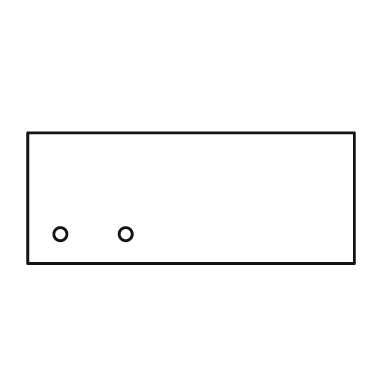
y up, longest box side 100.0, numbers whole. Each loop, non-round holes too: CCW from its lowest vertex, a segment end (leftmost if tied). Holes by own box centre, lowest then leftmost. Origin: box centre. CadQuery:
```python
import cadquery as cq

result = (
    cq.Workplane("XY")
    .moveTo(-50.0, -20.0)
    .lineTo(50.0, -20.0)
    .lineTo(50.0, 20.0)
    .lineTo(-50.0, 20.0)
    .close()
    .moveTo(-40.0, -11.0)
    .circle(2.0)
    .moveTo(-20.0, -11.0)
    .circle(2.0)
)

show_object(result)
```